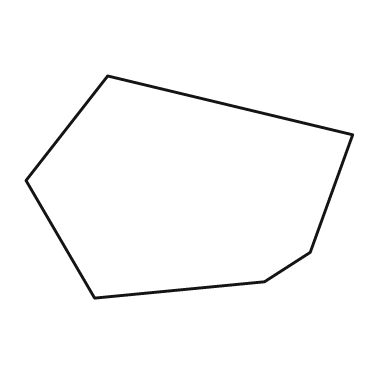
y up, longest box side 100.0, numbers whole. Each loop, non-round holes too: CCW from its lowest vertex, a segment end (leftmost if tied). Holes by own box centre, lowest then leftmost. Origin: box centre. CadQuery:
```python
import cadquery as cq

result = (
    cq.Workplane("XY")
    .moveTo(-29.0, -34.0)
    .lineTo(23.0, -29.0)
    .lineTo(37.0, -20.0)
    .lineTo(50.0, 16.0)
    .lineTo(-25.0, 34.0)
    .lineTo(-50.0, 2.0)
    .close()
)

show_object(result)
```